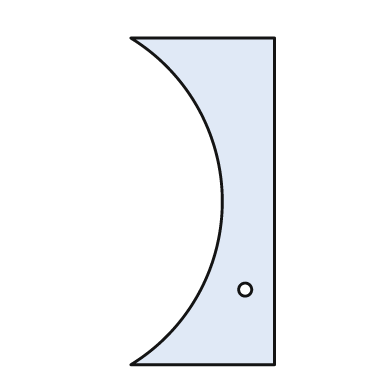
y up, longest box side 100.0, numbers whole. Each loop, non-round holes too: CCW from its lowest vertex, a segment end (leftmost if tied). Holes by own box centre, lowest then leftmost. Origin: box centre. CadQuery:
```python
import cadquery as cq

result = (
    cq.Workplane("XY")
    .moveTo(-22.0, -50.0)
    .lineTo(22.0, -50.0)
    .lineTo(22.0, 50.0)
    .lineTo(-22.0, 50.0)
    .threePointArc((6.0, 0.0), (-22.0, -50.0))
    .close()
    .moveTo(13.0, -27.0)
    .circle(2.0)
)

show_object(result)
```